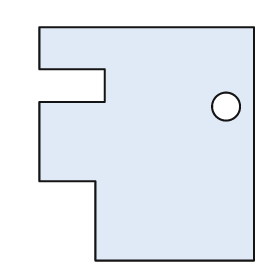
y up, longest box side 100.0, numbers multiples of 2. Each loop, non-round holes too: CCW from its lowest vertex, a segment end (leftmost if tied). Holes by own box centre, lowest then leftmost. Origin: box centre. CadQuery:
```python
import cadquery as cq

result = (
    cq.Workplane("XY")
    .moveTo(-22.0, -50.0)
    .lineTo(46.0, -50.0)
    .lineTo(46.0, 50.0)
    .lineTo(-46.0, 50.0)
    .lineTo(-46.0, 32.0)
    .lineTo(-18.0, 32.0)
    .lineTo(-18.0, 18.0)
    .lineTo(-46.0, 18.0)
    .lineTo(-46.0, -16.0)
    .lineTo(-22.0, -16.0)
    .close()
    .moveTo(34.0, 16.0)
    .circle(6.0)
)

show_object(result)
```